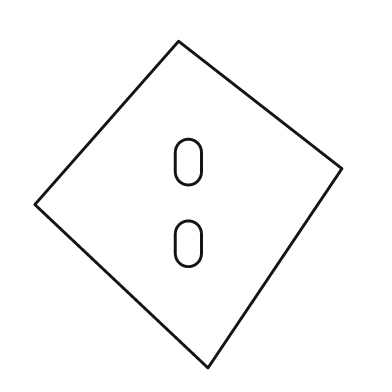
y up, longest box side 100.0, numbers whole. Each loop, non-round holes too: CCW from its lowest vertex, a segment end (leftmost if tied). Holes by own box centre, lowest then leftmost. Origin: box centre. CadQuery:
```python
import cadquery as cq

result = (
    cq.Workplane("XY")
    .moveTo(6.0, -50.0)
    .lineTo(47.0, 11.0)
    .lineTo(-3.0, 50.0)
    .lineTo(-47.0, 0.0)
    .close()
    .moveTo(-4.0, -15.0)
    .threePointArc((0.0, -19.0), (4.0, -15.0))
    .lineTo(4.0, -9.0)
    .threePointArc((0.0, -5.0), (-4.0, -9.0))
    .close()
    .moveTo(-4.0, 10.0)
    .threePointArc((0.0, 6.0), (4.0, 10.0))
    .lineTo(4.0, 16.0)
    .threePointArc((0.0, 20.0), (-4.0, 16.0))
    .close()
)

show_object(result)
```